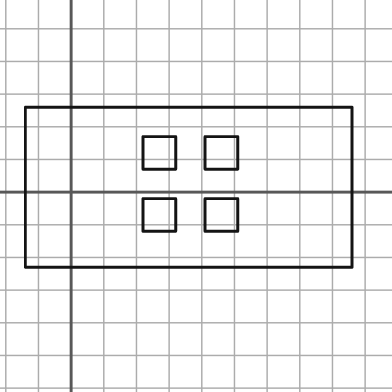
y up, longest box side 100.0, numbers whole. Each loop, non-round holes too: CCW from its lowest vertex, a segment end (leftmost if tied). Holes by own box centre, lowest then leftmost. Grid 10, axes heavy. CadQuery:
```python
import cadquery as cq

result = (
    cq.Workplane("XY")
    .moveTo(-14.0, -23.0)
    .lineTo(86.0, -23.0)
    .lineTo(86.0, 26.0)
    .lineTo(-14.0, 26.0)
    .close()
    .moveTo(22.0, -12.0)
    .lineTo(32.0, -12.0)
    .lineTo(32.0, -2.0)
    .lineTo(22.0, -2.0)
    .close()
    .moveTo(41.0, -12.0)
    .lineTo(51.0, -12.0)
    .lineTo(51.0, -2.0)
    .lineTo(41.0, -2.0)
    .close()
    .moveTo(22.0, 7.0)
    .lineTo(32.0, 7.0)
    .lineTo(32.0, 17.0)
    .lineTo(22.0, 17.0)
    .close()
    .moveTo(41.0, 7.0)
    .lineTo(51.0, 7.0)
    .lineTo(51.0, 17.0)
    .lineTo(41.0, 17.0)
    .close()
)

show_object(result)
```